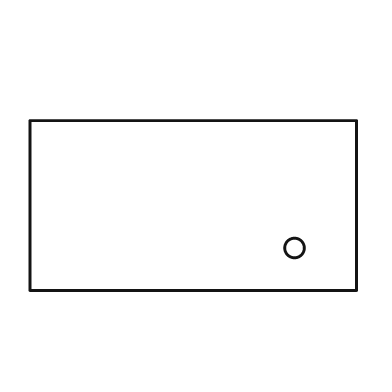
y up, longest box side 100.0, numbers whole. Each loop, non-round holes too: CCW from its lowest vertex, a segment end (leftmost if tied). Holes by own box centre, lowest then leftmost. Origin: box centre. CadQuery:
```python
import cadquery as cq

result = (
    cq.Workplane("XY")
    .moveTo(-50.0, -26.0)
    .lineTo(50.0, -26.0)
    .lineTo(50.0, 26.0)
    .lineTo(-50.0, 26.0)
    .close()
    .moveTo(31.0, -13.0)
    .circle(3.0)
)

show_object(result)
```